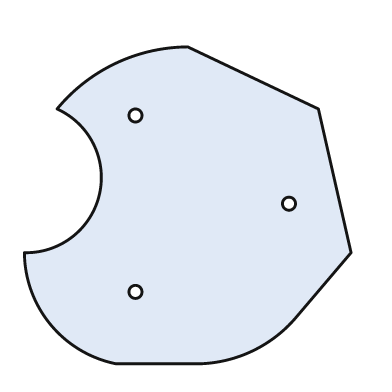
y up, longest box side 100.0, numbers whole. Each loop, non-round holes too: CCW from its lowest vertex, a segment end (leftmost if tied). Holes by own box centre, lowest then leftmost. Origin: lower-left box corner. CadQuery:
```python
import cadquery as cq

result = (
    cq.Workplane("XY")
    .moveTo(28.0, 0.0)
    .lineTo(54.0, 0.0)
    .threePointArc((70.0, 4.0), (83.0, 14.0))
    .lineTo(100.0, 34.0)
    .lineTo(90.0, 78.0)
    .lineTo(50.0, 97.0)
    .threePointArc((28.0, 92.0), (10.0, 78.0))
    .threePointArc((23.0, 52.0), (0.0, 34.0))
    .threePointArc((8.0, 12.0), (28.0, 0.0))
    .close()
    .moveTo(34.0, 22.0)
    .circle(2.0)
    .moveTo(81.0, 49.0)
    .circle(2.0)
    .moveTo(34.0, 76.0)
    .circle(2.0)
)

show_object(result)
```